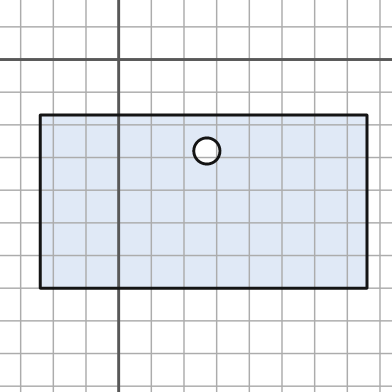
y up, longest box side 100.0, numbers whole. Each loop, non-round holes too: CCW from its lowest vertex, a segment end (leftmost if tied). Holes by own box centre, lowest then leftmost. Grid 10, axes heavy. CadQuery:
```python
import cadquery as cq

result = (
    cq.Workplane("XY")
    .moveTo(-24.0, -70.0)
    .lineTo(76.0, -70.0)
    .lineTo(76.0, -17.0)
    .lineTo(-24.0, -17.0)
    .close()
    .moveTo(27.0, -28.0)
    .circle(4.0)
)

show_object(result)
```